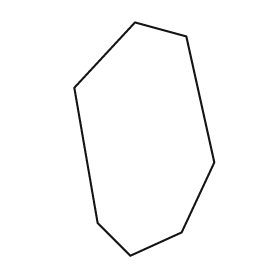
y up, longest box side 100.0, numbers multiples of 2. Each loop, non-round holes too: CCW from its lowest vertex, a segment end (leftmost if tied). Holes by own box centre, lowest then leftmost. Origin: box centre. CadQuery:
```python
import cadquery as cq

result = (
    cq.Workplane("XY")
    .moveTo(-6.0, -50.0)
    .lineTo(16.0, -40.0)
    .lineTo(30.0, -10.0)
    .lineTo(18.0, 44.0)
    .lineTo(-4.0, 50.0)
    .lineTo(-30.0, 22.0)
    .lineTo(-20.0, -36.0)
    .close()
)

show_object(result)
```